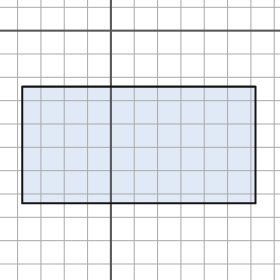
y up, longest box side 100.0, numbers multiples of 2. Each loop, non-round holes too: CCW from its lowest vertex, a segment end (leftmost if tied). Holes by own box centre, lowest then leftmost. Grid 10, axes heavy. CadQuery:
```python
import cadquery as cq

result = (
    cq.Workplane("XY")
    .moveTo(-38.0, -74.0)
    .lineTo(62.0, -74.0)
    .lineTo(62.0, -24.0)
    .lineTo(-38.0, -24.0)
    .close()
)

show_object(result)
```